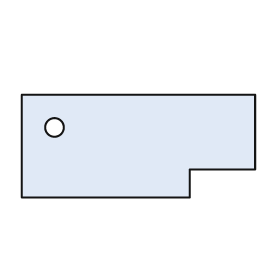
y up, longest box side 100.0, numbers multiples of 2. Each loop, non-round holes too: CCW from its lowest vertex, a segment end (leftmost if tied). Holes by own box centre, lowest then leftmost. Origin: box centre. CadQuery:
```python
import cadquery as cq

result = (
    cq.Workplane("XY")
    .moveTo(-50.0, -22.0)
    .lineTo(22.0, -22.0)
    .lineTo(22.0, -10.0)
    .lineTo(50.0, -10.0)
    .lineTo(50.0, 22.0)
    .lineTo(-50.0, 22.0)
    .close()
    .moveTo(-36.0, 8.0)
    .circle(4.0)
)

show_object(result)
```